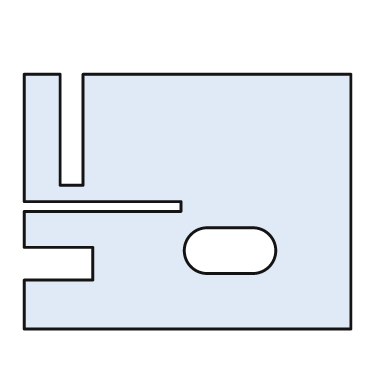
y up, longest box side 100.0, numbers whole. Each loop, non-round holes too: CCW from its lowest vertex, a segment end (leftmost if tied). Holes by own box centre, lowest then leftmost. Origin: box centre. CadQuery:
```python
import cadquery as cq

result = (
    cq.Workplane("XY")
    .moveTo(-50.0, -39.0)
    .lineTo(50.0, -39.0)
    .lineTo(50.0, 39.0)
    .lineTo(-32.0, 39.0)
    .lineTo(-32.0, 5.0)
    .lineTo(-39.0, 5.0)
    .lineTo(-39.0, 39.0)
    .lineTo(-50.0, 39.0)
    .lineTo(-50.0, 0.0)
    .lineTo(-2.0, 0.0)
    .lineTo(-2.0, -3.0)
    .lineTo(-50.0, -3.0)
    .lineTo(-50.0, -14.0)
    .lineTo(-29.0, -14.0)
    .lineTo(-29.0, -24.0)
    .lineTo(-50.0, -24.0)
    .close()
    .moveTo(6.0, -22.0)
    .lineTo(20.0, -22.0)
    .threePointArc((27.0, -15.0), (20.0, -8.0))
    .lineTo(6.0, -8.0)
    .threePointArc((-1.0, -15.0), (6.0, -22.0))
    .close()
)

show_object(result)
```